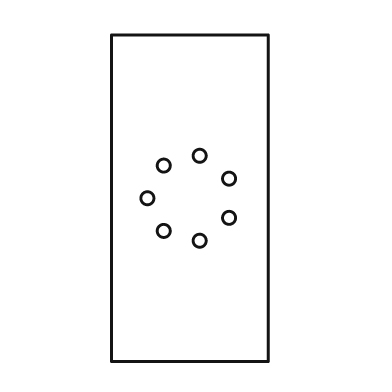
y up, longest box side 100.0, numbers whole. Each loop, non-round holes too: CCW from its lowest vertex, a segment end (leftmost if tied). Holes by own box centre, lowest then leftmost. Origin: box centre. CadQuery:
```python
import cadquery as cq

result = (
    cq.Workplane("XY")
    .moveTo(-24.0, -50.0)
    .lineTo(24.0, -50.0)
    .lineTo(24.0, 50.0)
    .lineTo(-24.0, 50.0)
    .close()
    .moveTo(3.0, -13.0)
    .circle(2.0)
    .moveTo(-8.0, -10.0)
    .circle(2.0)
    .moveTo(12.0, -6.0)
    .circle(2.0)
    .moveTo(-13.0, 0.0)
    .circle(2.0)
    .moveTo(12.0, 6.0)
    .circle(2.0)
    .moveTo(-8.0, 10.0)
    .circle(2.0)
    .moveTo(3.0, 13.0)
    .circle(2.0)
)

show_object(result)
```